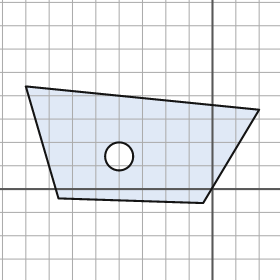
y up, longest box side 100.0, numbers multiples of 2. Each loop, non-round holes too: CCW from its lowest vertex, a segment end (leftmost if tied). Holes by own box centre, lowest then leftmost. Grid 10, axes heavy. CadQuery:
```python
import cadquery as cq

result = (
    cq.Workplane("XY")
    .moveTo(-4.0, -6.0)
    .lineTo(20.0, 34.0)
    .lineTo(-80.0, 44.0)
    .lineTo(-66.0, -4.0)
    .close()
    .moveTo(-40.0, 14.0)
    .circle(6.0)
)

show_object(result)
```